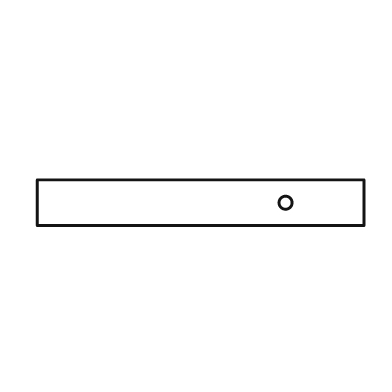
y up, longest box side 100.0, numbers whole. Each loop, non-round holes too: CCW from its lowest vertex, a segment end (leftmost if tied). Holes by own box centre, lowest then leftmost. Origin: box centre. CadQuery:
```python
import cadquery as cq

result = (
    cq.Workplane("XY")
    .moveTo(-50.0, -7.0)
    .lineTo(50.0, -7.0)
    .lineTo(50.0, 7.0)
    .lineTo(-50.0, 7.0)
    .close()
    .moveTo(26.0, 0.0)
    .circle(2.0)
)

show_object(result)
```